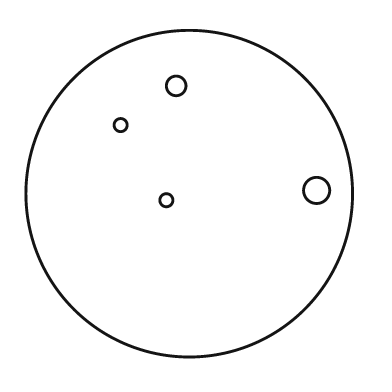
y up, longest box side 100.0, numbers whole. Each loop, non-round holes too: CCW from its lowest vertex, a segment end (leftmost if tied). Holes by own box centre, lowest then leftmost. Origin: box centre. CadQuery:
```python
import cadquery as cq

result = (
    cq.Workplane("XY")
    .moveTo(0.0, 0.0)
    .circle(50.0)
    .moveTo(-7.0, -2.0)
    .circle(2.0)
    .moveTo(39.0, 1.0)
    .circle(4.0)
    .moveTo(-21.0, 21.0)
    .circle(2.0)
    .moveTo(-4.0, 33.0)
    .circle(3.0)
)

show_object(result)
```